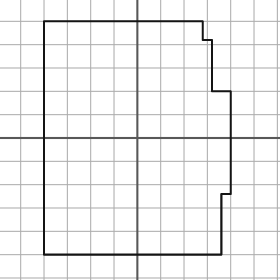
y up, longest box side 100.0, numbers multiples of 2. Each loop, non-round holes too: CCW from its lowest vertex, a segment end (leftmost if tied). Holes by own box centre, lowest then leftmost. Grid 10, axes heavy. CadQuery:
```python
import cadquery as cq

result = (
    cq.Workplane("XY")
    .moveTo(-40.0, -50.0)
    .lineTo(36.0, -50.0)
    .lineTo(36.0, -24.0)
    .lineTo(40.0, -24.0)
    .lineTo(40.0, 20.0)
    .lineTo(32.0, 20.0)
    .lineTo(32.0, 42.0)
    .lineTo(28.0, 42.0)
    .lineTo(28.0, 50.0)
    .lineTo(-40.0, 50.0)
    .close()
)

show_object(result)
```